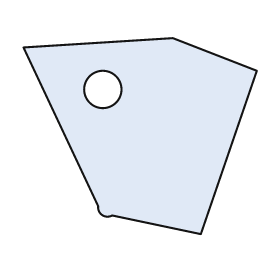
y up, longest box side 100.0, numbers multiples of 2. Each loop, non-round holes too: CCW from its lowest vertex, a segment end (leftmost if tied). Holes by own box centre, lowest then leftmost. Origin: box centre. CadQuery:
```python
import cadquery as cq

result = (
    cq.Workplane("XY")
    .moveTo(26.0, -42.0)
    .lineTo(50.0, 28.0)
    .lineTo(14.0, 42.0)
    .lineTo(-50.0, 38.0)
    .lineTo(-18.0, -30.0)
    .threePointArc((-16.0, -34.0), (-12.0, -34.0))
    .close()
    .moveTo(-16.0, 20.0)
    .circle(8.0)
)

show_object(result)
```